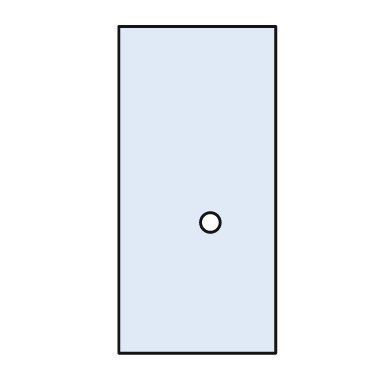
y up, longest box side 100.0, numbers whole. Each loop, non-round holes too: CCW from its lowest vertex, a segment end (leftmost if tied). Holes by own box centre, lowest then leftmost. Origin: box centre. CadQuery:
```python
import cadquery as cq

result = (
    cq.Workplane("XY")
    .moveTo(-24.0, -50.0)
    .lineTo(24.0, -50.0)
    .lineTo(24.0, 50.0)
    .lineTo(-24.0, 50.0)
    .close()
    .moveTo(4.0, -10.0)
    .circle(3.0)
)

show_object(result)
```